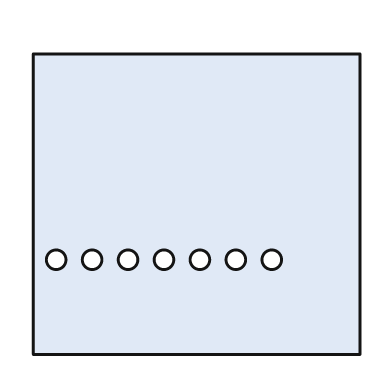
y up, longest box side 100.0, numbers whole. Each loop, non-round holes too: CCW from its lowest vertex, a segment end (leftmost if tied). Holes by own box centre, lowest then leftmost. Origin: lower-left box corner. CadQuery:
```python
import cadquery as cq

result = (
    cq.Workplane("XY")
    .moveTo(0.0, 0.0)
    .lineTo(100.0, 0.0)
    .lineTo(100.0, 92.0)
    .lineTo(0.0, 92.0)
    .close()
    .moveTo(7.0, 29.0)
    .circle(3.0)
    .moveTo(18.0, 29.0)
    .circle(3.0)
    .moveTo(29.0, 29.0)
    .circle(3.0)
    .moveTo(40.0, 29.0)
    .circle(3.0)
    .moveTo(51.0, 29.0)
    .circle(3.0)
    .moveTo(62.0, 29.0)
    .circle(3.0)
    .moveTo(73.0, 29.0)
    .circle(3.0)
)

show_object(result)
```